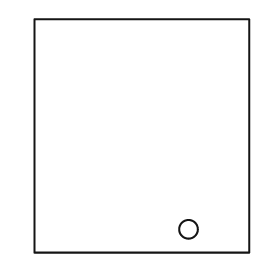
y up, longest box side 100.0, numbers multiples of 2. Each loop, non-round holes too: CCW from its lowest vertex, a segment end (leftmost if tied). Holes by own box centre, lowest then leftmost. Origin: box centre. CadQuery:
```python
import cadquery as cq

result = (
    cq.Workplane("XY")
    .moveTo(-46.0, -50.0)
    .lineTo(46.0, -50.0)
    .lineTo(46.0, 50.0)
    .lineTo(-46.0, 50.0)
    .close()
    .moveTo(20.0, -40.0)
    .circle(4.0)
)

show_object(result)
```